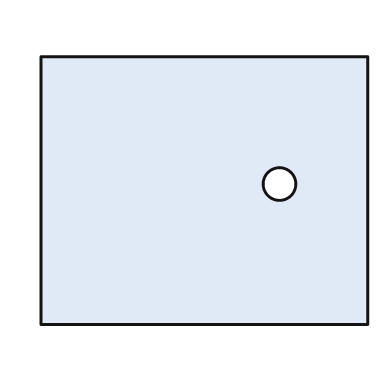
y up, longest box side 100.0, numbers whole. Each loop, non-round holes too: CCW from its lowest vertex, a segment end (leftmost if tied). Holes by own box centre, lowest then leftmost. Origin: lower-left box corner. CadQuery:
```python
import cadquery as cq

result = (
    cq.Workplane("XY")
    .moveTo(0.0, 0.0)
    .lineTo(100.0, 0.0)
    .lineTo(100.0, 82.0)
    .lineTo(0.0, 82.0)
    .close()
    .moveTo(73.0, 43.0)
    .circle(5.0)
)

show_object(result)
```